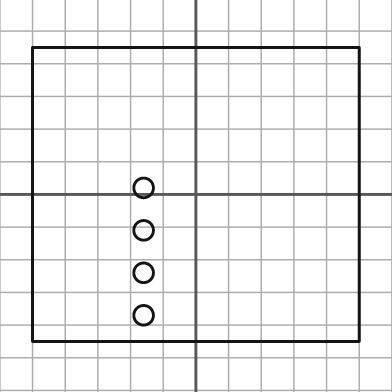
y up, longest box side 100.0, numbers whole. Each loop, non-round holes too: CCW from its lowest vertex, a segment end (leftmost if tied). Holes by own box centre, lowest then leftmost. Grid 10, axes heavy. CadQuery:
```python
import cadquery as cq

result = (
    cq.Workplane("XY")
    .moveTo(-50.0, -45.0)
    .lineTo(50.0, -45.0)
    .lineTo(50.0, 45.0)
    .lineTo(-50.0, 45.0)
    .close()
    .moveTo(-16.0, -37.0)
    .circle(3.0)
    .moveTo(-16.0, -24.0)
    .circle(3.0)
    .moveTo(-16.0, -11.0)
    .circle(3.0)
    .moveTo(-16.0, 2.0)
    .circle(3.0)
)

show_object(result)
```